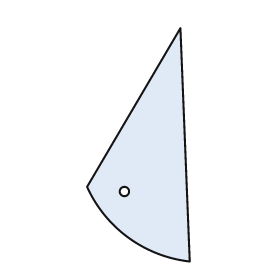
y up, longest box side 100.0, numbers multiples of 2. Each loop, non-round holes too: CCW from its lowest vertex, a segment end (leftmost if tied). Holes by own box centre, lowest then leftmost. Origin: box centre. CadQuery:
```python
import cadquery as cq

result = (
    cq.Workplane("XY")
    .moveTo(22.0, -50.0)
    .lineTo(18.0, 50.0)
    .lineTo(-22.0, -18.0)
    .threePointArc((-4.0, -40.0), (22.0, -50.0))
    .close()
    .moveTo(-6.0, -20.0)
    .circle(2.0)
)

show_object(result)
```